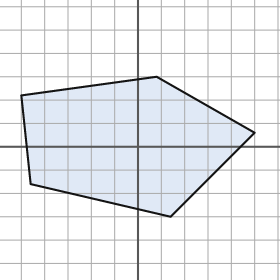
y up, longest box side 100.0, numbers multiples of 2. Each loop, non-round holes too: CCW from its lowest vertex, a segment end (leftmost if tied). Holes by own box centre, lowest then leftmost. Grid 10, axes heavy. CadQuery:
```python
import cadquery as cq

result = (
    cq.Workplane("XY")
    .moveTo(14.0, -30.0)
    .lineTo(50.0, 6.0)
    .lineTo(8.0, 30.0)
    .lineTo(-50.0, 22.0)
    .lineTo(-46.0, -16.0)
    .close()
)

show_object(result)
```